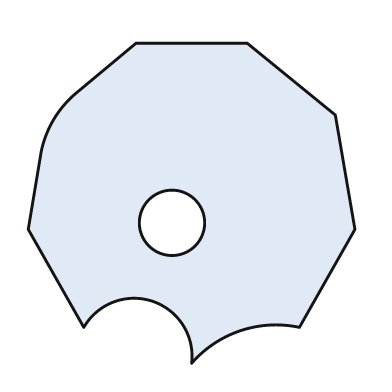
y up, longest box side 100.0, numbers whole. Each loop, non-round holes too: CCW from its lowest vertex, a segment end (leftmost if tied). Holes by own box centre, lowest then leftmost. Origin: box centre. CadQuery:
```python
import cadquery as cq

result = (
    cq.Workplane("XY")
    .moveTo(0.0, -49.0)
    .threePointArc((15.0, -39.0), (33.0, -38.0))
    .lineTo(50.0, -8.0)
    .lineTo(44.0, 27.0)
    .lineTo(17.0, 49.0)
    .lineTo(-17.0, 49.0)
    .lineTo(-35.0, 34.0)
    .threePointArc((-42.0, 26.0), (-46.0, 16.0))
    .lineTo(-50.0, -8.0)
    .lineTo(-33.0, -38.0)
    .threePointArc((-12.0, -30.0), (0.0, -49.0))
    .close()
    .moveTo(-6.0, -6.0)
    .circle(10.0)
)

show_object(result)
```